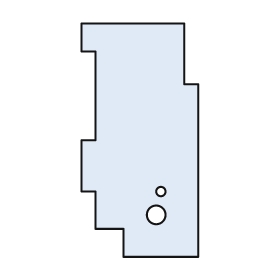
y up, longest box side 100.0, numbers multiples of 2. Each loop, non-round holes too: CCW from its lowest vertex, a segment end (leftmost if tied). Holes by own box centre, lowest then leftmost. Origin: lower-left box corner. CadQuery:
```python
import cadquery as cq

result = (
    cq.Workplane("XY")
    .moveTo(18.0, 0.0)
    .lineTo(50.0, 0.0)
    .lineTo(50.0, 74.0)
    .lineTo(44.0, 74.0)
    .lineTo(44.0, 100.0)
    .lineTo(0.0, 100.0)
    .lineTo(0.0, 88.0)
    .lineTo(6.0, 88.0)
    .lineTo(6.0, 50.0)
    .lineTo(0.0, 50.0)
    .lineTo(0.0, 28.0)
    .lineTo(6.0, 28.0)
    .lineTo(6.0, 12.0)
    .lineTo(18.0, 12.0)
    .close()
    .moveTo(32.0, 18.0)
    .circle(4.0)
    .moveTo(34.0, 28.0)
    .circle(2.0)
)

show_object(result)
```